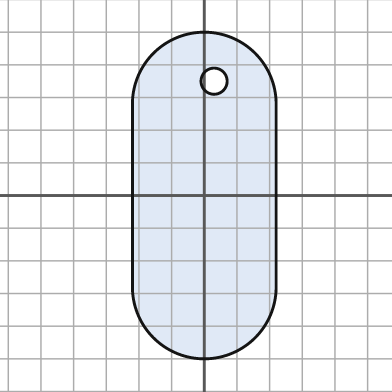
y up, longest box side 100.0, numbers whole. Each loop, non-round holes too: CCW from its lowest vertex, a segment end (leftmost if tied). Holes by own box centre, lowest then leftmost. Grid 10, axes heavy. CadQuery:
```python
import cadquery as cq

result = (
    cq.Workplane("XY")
    .moveTo(-22.0, -28.0)
    .threePointArc((0.0, -50.0), (22.0, -28.0))
    .lineTo(22.0, 28.0)
    .threePointArc((0.0, 50.0), (-22.0, 28.0))
    .close()
    .moveTo(3.0, 35.0)
    .circle(4.0)
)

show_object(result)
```